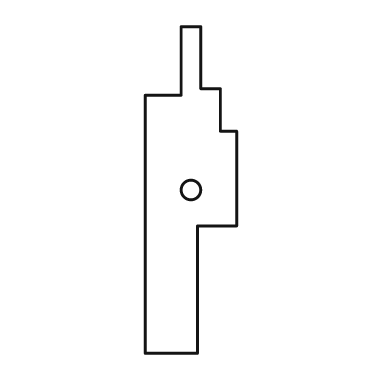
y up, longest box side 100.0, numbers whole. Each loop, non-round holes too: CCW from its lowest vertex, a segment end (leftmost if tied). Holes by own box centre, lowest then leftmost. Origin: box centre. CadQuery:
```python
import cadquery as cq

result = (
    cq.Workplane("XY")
    .moveTo(-14.0, -50.0)
    .lineTo(2.0, -50.0)
    .lineTo(2.0, -11.0)
    .lineTo(14.0, -11.0)
    .lineTo(14.0, 18.0)
    .lineTo(9.0, 18.0)
    .lineTo(9.0, 31.0)
    .lineTo(3.0, 31.0)
    .lineTo(3.0, 50.0)
    .lineTo(-3.0, 50.0)
    .lineTo(-3.0, 29.0)
    .lineTo(-14.0, 29.0)
    .close()
    .moveTo(0.0, 0.0)
    .circle(3.0)
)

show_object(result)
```